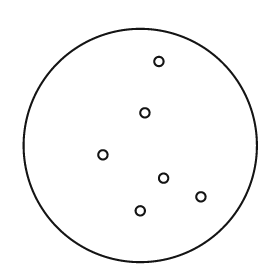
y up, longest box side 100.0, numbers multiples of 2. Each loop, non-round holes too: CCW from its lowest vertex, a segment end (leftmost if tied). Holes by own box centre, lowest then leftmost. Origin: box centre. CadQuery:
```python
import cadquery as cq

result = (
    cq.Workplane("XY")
    .moveTo(0.0, 0.0)
    .circle(50.0)
    .moveTo(0.0, -28.0)
    .circle(2.0)
    .moveTo(26.0, -22.0)
    .circle(2.0)
    .moveTo(10.0, -14.0)
    .circle(2.0)
    .moveTo(-16.0, -4.0)
    .circle(2.0)
    .moveTo(2.0, 14.0)
    .circle(2.0)
    .moveTo(8.0, 36.0)
    .circle(2.0)
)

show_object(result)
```